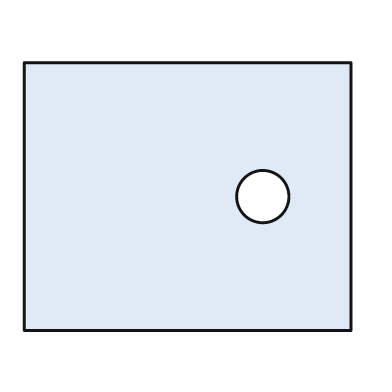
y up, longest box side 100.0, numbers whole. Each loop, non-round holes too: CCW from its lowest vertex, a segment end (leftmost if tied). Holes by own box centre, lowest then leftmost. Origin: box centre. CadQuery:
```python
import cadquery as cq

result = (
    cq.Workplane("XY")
    .moveTo(-50.0, -41.0)
    .lineTo(50.0, -41.0)
    .lineTo(50.0, 41.0)
    .lineTo(-50.0, 41.0)
    .close()
    .moveTo(23.0, 0.0)
    .circle(8.0)
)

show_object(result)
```